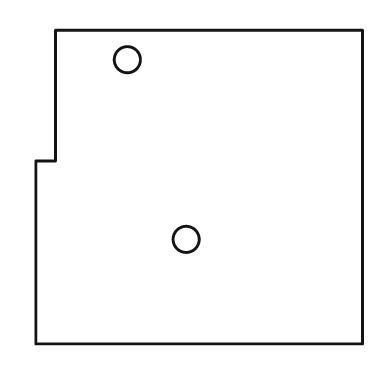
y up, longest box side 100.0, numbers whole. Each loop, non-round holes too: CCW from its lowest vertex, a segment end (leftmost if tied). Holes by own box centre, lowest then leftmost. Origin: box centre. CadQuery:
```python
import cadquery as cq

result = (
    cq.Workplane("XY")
    .moveTo(-50.0, -48.0)
    .lineTo(50.0, -48.0)
    .lineTo(50.0, 48.0)
    .lineTo(-44.0, 48.0)
    .lineTo(-44.0, 8.0)
    .lineTo(-50.0, 8.0)
    .close()
    .moveTo(-4.0, -16.0)
    .circle(4.0)
    .moveTo(-22.0, 39.0)
    .circle(4.0)
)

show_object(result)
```